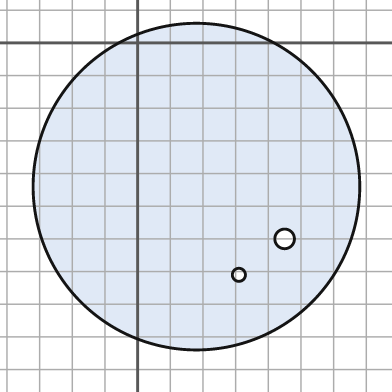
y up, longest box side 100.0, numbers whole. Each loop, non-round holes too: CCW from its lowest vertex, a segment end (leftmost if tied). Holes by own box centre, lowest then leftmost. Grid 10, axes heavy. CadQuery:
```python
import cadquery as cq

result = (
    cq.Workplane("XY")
    .moveTo(18.0, -44.0)
    .circle(50.0)
    .moveTo(31.0, -71.0)
    .circle(2.0)
    .moveTo(45.0, -60.0)
    .circle(3.0)
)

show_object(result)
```